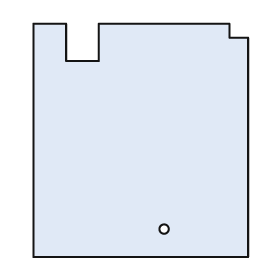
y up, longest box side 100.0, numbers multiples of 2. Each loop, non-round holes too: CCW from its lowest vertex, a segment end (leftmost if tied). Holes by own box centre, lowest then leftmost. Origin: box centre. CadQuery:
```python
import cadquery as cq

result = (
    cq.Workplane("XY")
    .moveTo(-46.0, -50.0)
    .lineTo(46.0, -50.0)
    .lineTo(46.0, 44.0)
    .lineTo(38.0, 44.0)
    .lineTo(38.0, 50.0)
    .lineTo(-18.0, 50.0)
    .lineTo(-18.0, 34.0)
    .lineTo(-32.0, 34.0)
    .lineTo(-32.0, 50.0)
    .lineTo(-46.0, 50.0)
    .close()
    .moveTo(10.0, -38.0)
    .circle(2.0)
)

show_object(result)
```